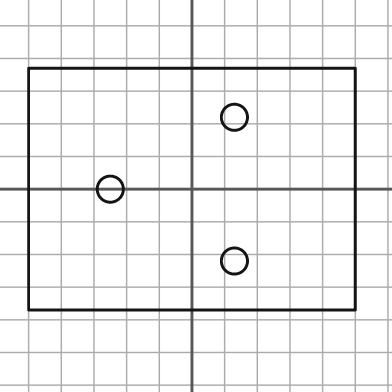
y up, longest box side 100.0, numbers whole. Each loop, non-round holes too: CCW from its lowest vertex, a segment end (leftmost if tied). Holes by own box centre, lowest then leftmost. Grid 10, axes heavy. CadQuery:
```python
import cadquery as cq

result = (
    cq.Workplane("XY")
    .moveTo(-50.0, -37.0)
    .lineTo(50.0, -37.0)
    .lineTo(50.0, 37.0)
    .lineTo(-50.0, 37.0)
    .close()
    .moveTo(13.0, -22.0)
    .circle(4.0)
    .moveTo(-25.0, 0.0)
    .circle(4.0)
    .moveTo(13.0, 22.0)
    .circle(4.0)
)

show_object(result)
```